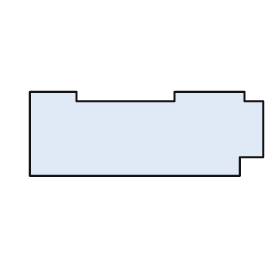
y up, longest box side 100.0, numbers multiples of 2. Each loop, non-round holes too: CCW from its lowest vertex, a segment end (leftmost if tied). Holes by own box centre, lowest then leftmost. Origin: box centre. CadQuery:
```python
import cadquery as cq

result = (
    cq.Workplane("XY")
    .moveTo(-50.0, -18.0)
    .lineTo(40.0, -18.0)
    .lineTo(40.0, -10.0)
    .lineTo(50.0, -10.0)
    .lineTo(50.0, 14.0)
    .lineTo(42.0, 14.0)
    .lineTo(42.0, 18.0)
    .lineTo(12.0, 18.0)
    .lineTo(12.0, 14.0)
    .lineTo(-30.0, 14.0)
    .lineTo(-30.0, 18.0)
    .lineTo(-50.0, 18.0)
    .close()
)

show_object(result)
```